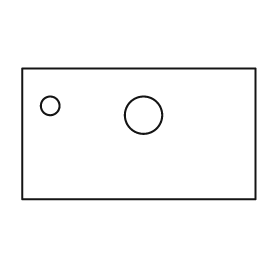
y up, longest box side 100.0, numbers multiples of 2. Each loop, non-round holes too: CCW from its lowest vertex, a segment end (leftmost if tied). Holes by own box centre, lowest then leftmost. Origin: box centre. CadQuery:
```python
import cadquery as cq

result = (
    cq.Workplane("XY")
    .moveTo(-50.0, -28.0)
    .lineTo(50.0, -28.0)
    .lineTo(50.0, 28.0)
    .lineTo(-50.0, 28.0)
    .close()
    .moveTo(2.0, 8.0)
    .circle(8.0)
    .moveTo(-38.0, 12.0)
    .circle(4.0)
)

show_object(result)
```